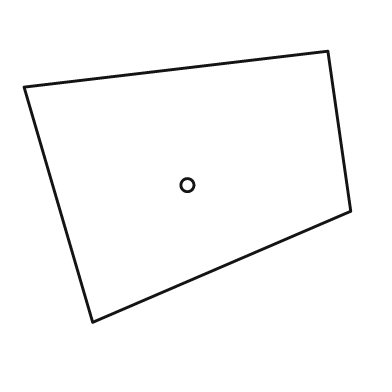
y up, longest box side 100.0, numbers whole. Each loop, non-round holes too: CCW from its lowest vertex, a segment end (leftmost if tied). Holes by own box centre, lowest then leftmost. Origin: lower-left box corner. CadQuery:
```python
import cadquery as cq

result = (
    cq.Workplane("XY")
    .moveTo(21.0, 0.0)
    .lineTo(100.0, 34.0)
    .lineTo(93.0, 83.0)
    .lineTo(0.0, 72.0)
    .close()
    .moveTo(50.0, 42.0)
    .circle(2.0)
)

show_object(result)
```